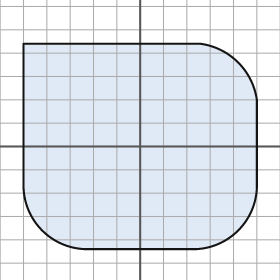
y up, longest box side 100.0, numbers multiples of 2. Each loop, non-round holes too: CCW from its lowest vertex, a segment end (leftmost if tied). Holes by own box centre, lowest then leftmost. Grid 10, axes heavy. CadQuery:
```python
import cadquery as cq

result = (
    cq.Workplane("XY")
    .moveTo(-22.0, -44.0)
    .lineTo(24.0, -44.0)
    .threePointArc((42.0, -36.0), (50.0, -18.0))
    .lineTo(50.0, 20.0)
    .threePointArc((42.0, 36.0), (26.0, 44.0))
    .lineTo(-50.0, 44.0)
    .lineTo(-50.0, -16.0)
    .threePointArc((-42.0, -36.0), (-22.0, -44.0))
    .close()
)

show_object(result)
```